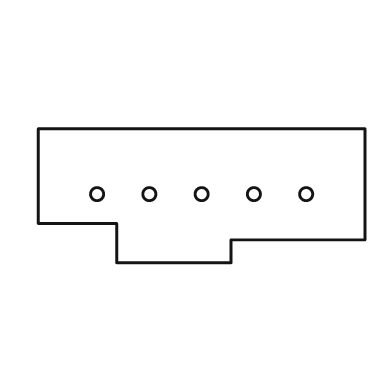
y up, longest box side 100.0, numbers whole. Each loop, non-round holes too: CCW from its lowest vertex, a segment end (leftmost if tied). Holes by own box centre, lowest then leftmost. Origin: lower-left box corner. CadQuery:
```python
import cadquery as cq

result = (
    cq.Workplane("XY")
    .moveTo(24.0, 0.0)
    .lineTo(59.0, 0.0)
    .lineTo(59.0, 7.0)
    .lineTo(100.0, 7.0)
    .lineTo(100.0, 41.0)
    .lineTo(0.0, 41.0)
    .lineTo(0.0, 12.0)
    .lineTo(24.0, 12.0)
    .close()
    .moveTo(18.0, 21.0)
    .circle(2.0)
    .moveTo(34.0, 21.0)
    .circle(2.0)
    .moveTo(50.0, 21.0)
    .circle(2.0)
    .moveTo(66.0, 21.0)
    .circle(2.0)
    .moveTo(82.0, 21.0)
    .circle(2.0)
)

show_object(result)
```